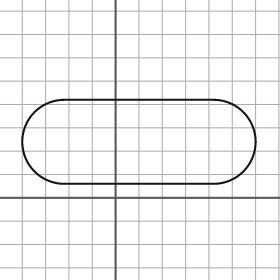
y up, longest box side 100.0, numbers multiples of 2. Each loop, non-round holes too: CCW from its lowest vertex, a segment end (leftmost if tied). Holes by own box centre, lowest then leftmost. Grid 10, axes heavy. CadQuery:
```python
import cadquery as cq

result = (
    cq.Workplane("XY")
    .moveTo(-22.0, 6.0)
    .lineTo(42.0, 6.0)
    .threePointArc((60.0, 24.0), (42.0, 42.0))
    .lineTo(-22.0, 42.0)
    .threePointArc((-40.0, 24.0), (-22.0, 6.0))
    .close()
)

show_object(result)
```